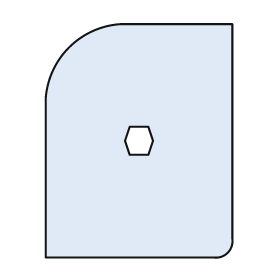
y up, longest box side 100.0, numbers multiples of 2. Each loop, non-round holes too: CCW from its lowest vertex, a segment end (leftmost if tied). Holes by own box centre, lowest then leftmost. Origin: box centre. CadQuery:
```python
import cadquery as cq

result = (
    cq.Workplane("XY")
    .moveTo(-40.0, -50.0)
    .lineTo(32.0, -50.0)
    .threePointArc((38.0, -48.0), (40.0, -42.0))
    .lineTo(40.0, 50.0)
    .lineTo(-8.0, 50.0)
    .threePointArc((-30.0, 40.0), (-40.0, 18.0))
    .close()
    .moveTo(-4.0, -6.0)
    .lineTo(4.0, -6.0)
    .lineTo(6.0, 0.0)
    .lineTo(4.0, 6.0)
    .lineTo(-4.0, 6.0)
    .lineTo(-6.0, 0.0)
    .close()
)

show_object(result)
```